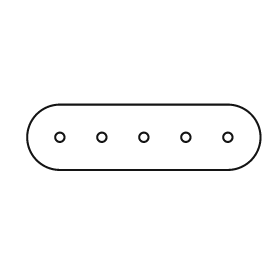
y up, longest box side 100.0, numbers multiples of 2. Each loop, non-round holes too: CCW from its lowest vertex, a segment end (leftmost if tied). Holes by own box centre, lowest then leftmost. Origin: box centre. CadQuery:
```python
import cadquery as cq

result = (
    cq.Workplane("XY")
    .moveTo(-36.0, -14.0)
    .lineTo(36.0, -14.0)
    .threePointArc((50.0, 0.0), (36.0, 14.0))
    .lineTo(-36.0, 14.0)
    .threePointArc((-50.0, 0.0), (-36.0, -14.0))
    .close()
    .moveTo(-36.0, 0.0)
    .circle(2.0)
    .moveTo(-18.0, 0.0)
    .circle(2.0)
    .moveTo(0.0, 0.0)
    .circle(2.0)
    .moveTo(18.0, 0.0)
    .circle(2.0)
    .moveTo(36.0, 0.0)
    .circle(2.0)
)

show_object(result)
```